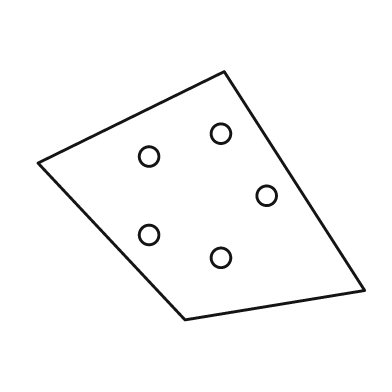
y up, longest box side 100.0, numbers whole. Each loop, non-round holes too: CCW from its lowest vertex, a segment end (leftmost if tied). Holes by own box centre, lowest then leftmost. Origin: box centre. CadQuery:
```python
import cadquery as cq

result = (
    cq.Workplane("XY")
    .moveTo(-5.0, -38.0)
    .lineTo(50.0, -29.0)
    .lineTo(7.0, 38.0)
    .lineTo(-50.0, 10.0)
    .close()
    .moveTo(6.0, -19.0)
    .circle(3.0)
    .moveTo(-16.0, -12.0)
    .circle(3.0)
    .moveTo(20.0, 0.0)
    .circle(3.0)
    .moveTo(-16.0, 12.0)
    .circle(3.0)
    .moveTo(6.0, 19.0)
    .circle(3.0)
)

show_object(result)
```